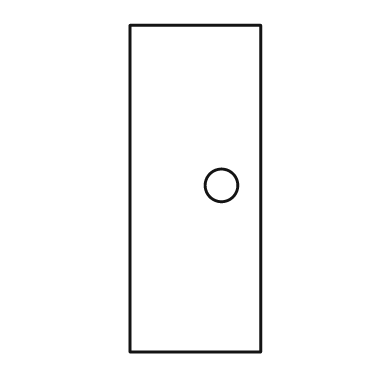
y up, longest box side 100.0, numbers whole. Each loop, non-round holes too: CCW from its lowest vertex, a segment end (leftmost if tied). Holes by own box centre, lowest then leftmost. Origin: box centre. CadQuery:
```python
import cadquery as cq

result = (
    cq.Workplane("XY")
    .moveTo(-20.0, -50.0)
    .lineTo(20.0, -50.0)
    .lineTo(20.0, 50.0)
    .lineTo(-20.0, 50.0)
    .close()
    .moveTo(8.0, 1.0)
    .circle(5.0)
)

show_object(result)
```